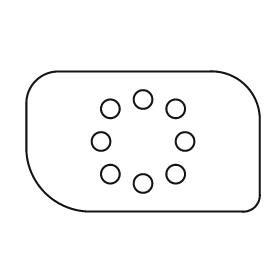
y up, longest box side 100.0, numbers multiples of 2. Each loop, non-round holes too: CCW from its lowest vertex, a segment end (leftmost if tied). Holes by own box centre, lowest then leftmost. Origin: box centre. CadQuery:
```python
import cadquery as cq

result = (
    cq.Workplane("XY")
    .moveTo(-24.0, -30.0)
    .lineTo(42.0, -30.0)
    .threePointArc((48.0, -28.0), (50.0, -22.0))
    .lineTo(50.0, 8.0)
    .threePointArc((44.0, 24.0), (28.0, 30.0))
    .lineTo(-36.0, 30.0)
    .threePointArc((-46.0, 26.0), (-50.0, 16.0))
    .lineTo(-50.0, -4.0)
    .threePointArc((-42.0, -22.0), (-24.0, -30.0))
    .close()
    .moveTo(0.0, -18.0)
    .circle(4.0)
    .moveTo(-14.0, -14.0)
    .circle(4.0)
    .moveTo(14.0, -14.0)
    .circle(4.0)
    .moveTo(-18.0, 0.0)
    .circle(4.0)
    .moveTo(18.0, 0.0)
    .circle(4.0)
    .moveTo(-14.0, 14.0)
    .circle(4.0)
    .moveTo(14.0, 14.0)
    .circle(4.0)
    .moveTo(0.0, 18.0)
    .circle(4.0)
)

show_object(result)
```